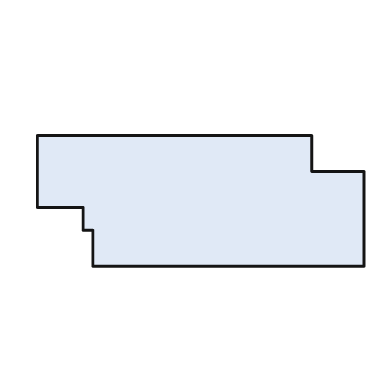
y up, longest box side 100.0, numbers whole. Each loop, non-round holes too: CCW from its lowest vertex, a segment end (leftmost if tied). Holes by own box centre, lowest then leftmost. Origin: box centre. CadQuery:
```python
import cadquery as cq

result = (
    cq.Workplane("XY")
    .moveTo(-33.0, -20.0)
    .lineTo(50.0, -20.0)
    .lineTo(50.0, 9.0)
    .lineTo(34.0, 9.0)
    .lineTo(34.0, 20.0)
    .lineTo(-50.0, 20.0)
    .lineTo(-50.0, -2.0)
    .lineTo(-36.0, -2.0)
    .lineTo(-36.0, -9.0)
    .lineTo(-33.0, -9.0)
    .close()
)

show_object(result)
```